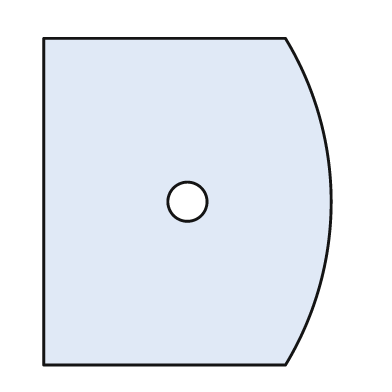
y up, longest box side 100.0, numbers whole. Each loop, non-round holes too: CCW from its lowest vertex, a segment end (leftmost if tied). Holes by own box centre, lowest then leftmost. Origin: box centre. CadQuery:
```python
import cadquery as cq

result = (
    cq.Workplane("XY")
    .moveTo(-44.0, -50.0)
    .lineTo(30.0, -50.0)
    .threePointArc((44.0, 0.0), (30.0, 50.0))
    .lineTo(-44.0, 50.0)
    .close()
    .moveTo(0.0, 0.0)
    .circle(6.0)
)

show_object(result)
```